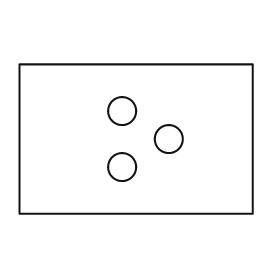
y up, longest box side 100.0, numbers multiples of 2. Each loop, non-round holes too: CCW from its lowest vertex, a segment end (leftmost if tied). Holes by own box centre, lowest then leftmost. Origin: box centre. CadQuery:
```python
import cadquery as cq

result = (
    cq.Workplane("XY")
    .moveTo(-50.0, -32.0)
    .lineTo(50.0, -32.0)
    .lineTo(50.0, 32.0)
    .lineTo(-50.0, 32.0)
    .close()
    .moveTo(-6.0, -12.0)
    .circle(6.0)
    .moveTo(14.0, 0.0)
    .circle(6.0)
    .moveTo(-6.0, 12.0)
    .circle(6.0)
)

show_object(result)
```